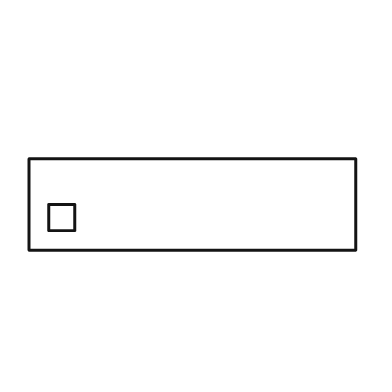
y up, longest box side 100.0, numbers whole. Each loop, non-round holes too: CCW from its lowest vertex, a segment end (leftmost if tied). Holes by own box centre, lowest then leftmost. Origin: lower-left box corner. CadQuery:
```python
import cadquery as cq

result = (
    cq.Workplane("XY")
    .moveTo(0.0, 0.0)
    .lineTo(100.0, 0.0)
    .lineTo(100.0, 28.0)
    .lineTo(0.0, 28.0)
    .close()
    .moveTo(6.0, 6.0)
    .lineTo(14.0, 6.0)
    .lineTo(14.0, 14.0)
    .lineTo(6.0, 14.0)
    .close()
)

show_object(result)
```